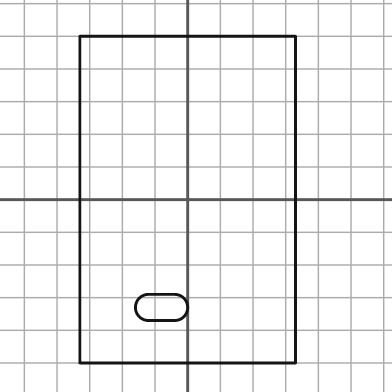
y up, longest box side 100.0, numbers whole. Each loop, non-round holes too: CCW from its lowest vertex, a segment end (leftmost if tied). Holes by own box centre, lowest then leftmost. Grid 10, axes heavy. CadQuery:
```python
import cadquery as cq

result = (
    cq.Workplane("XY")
    .moveTo(-33.0, -50.0)
    .lineTo(33.0, -50.0)
    .lineTo(33.0, 50.0)
    .lineTo(-33.0, 50.0)
    .close()
    .moveTo(-12.0, -37.0)
    .lineTo(-4.0, -37.0)
    .threePointArc((0.0, -33.0), (-4.0, -29.0))
    .lineTo(-12.0, -29.0)
    .threePointArc((-16.0, -33.0), (-12.0, -37.0))
    .close()
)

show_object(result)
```